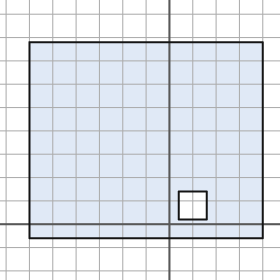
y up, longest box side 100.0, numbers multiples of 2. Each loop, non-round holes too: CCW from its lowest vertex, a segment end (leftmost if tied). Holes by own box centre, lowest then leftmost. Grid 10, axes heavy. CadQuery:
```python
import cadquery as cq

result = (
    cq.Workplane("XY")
    .moveTo(-60.0, -6.0)
    .lineTo(40.0, -6.0)
    .lineTo(40.0, 78.0)
    .lineTo(-60.0, 78.0)
    .close()
    .moveTo(4.0, 2.0)
    .lineTo(16.0, 2.0)
    .lineTo(16.0, 14.0)
    .lineTo(4.0, 14.0)
    .close()
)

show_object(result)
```